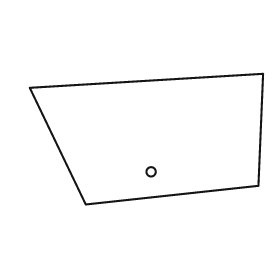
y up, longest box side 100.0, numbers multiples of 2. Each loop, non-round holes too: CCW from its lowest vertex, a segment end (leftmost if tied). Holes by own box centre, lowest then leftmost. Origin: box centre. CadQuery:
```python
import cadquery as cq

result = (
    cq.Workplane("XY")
    .moveTo(-26.0, -28.0)
    .lineTo(48.0, -20.0)
    .lineTo(50.0, 28.0)
    .lineTo(-50.0, 22.0)
    .close()
    .moveTo(2.0, -14.0)
    .circle(2.0)
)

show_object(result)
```